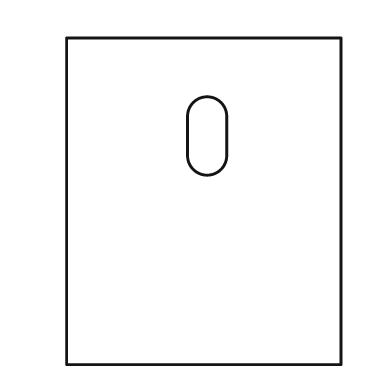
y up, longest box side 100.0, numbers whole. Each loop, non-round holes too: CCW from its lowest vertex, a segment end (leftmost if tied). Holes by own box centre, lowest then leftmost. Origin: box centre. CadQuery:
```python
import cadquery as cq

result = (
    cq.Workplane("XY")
    .moveTo(-42.0, -50.0)
    .lineTo(42.0, -50.0)
    .lineTo(42.0, 50.0)
    .lineTo(-42.0, 50.0)
    .close()
    .moveTo(-5.0, 14.0)
    .threePointArc((1.0, 8.0), (7.0, 14.0))
    .lineTo(7.0, 26.0)
    .threePointArc((1.0, 32.0), (-5.0, 26.0))
    .close()
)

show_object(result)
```